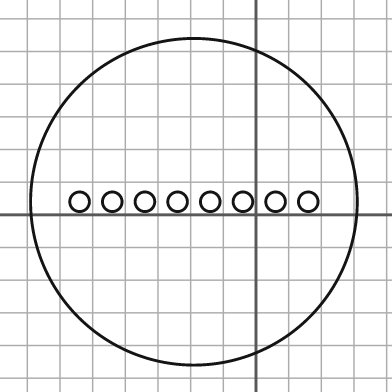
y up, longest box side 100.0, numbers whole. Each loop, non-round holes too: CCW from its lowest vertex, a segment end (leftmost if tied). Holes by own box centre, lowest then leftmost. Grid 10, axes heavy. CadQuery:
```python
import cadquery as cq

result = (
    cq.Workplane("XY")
    .moveTo(-19.0, 4.0)
    .circle(50.0)
    .moveTo(-54.0, 4.0)
    .circle(3.0)
    .moveTo(-44.0, 4.0)
    .circle(3.0)
    .moveTo(-34.0, 4.0)
    .circle(3.0)
    .moveTo(-24.0, 4.0)
    .circle(3.0)
    .moveTo(-14.0, 4.0)
    .circle(3.0)
    .moveTo(-4.0, 4.0)
    .circle(3.0)
    .moveTo(6.0, 4.0)
    .circle(3.0)
    .moveTo(16.0, 4.0)
    .circle(3.0)
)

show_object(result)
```